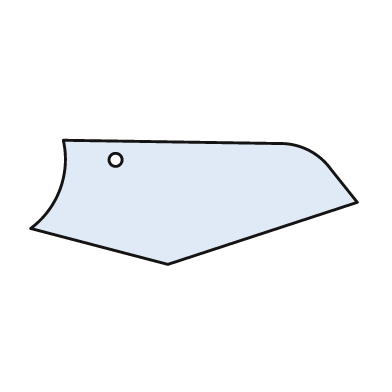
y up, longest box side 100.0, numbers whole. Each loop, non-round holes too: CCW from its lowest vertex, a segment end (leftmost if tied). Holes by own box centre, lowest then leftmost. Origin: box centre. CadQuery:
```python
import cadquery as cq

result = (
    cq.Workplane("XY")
    .moveTo(-8.0, -19.0)
    .lineTo(50.0, 0.0)
    .lineTo(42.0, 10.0)
    .threePointArc((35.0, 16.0), (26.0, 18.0))
    .lineTo(-40.0, 19.0)
    .threePointArc((-41.0, 4.0), (-50.0, -8.0))
    .close()
    .moveTo(-24.0, 13.0)
    .circle(2.0)
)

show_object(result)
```